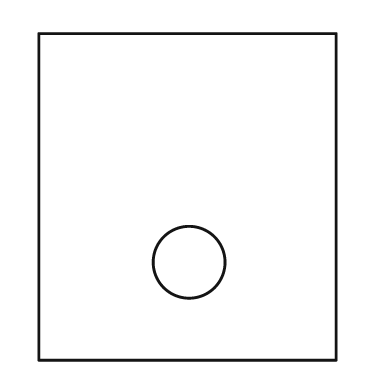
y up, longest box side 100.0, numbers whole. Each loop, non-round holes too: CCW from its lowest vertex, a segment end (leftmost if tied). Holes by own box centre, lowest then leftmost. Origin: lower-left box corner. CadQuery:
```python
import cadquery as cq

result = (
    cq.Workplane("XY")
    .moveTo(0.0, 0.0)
    .lineTo(91.0, 0.0)
    .lineTo(91.0, 100.0)
    .lineTo(0.0, 100.0)
    .close()
    .moveTo(46.0, 30.0)
    .circle(11.0)
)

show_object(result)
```